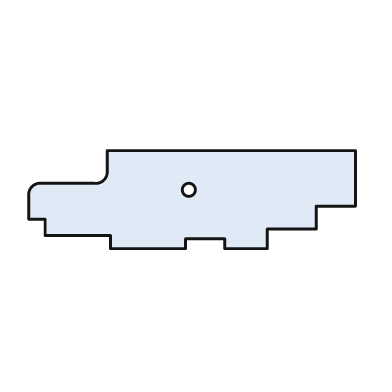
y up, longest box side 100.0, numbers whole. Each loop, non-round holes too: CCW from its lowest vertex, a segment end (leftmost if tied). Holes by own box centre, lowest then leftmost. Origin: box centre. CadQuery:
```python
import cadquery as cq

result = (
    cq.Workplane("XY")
    .moveTo(-25.0, -15.0)
    .lineTo(-2.0, -15.0)
    .lineTo(-2.0, -12.0)
    .lineTo(10.0, -12.0)
    .lineTo(10.0, -15.0)
    .lineTo(23.0, -15.0)
    .lineTo(23.0, -9.0)
    .lineTo(38.0, -9.0)
    .lineTo(38.0, -2.0)
    .lineTo(50.0, -2.0)
    .lineTo(50.0, 15.0)
    .lineTo(-26.0, 15.0)
    .lineTo(-26.0, 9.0)
    .threePointArc((-27.0, 6.0), (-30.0, 5.0))
    .lineTo(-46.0, 5.0)
    .threePointArc((-49.0, 4.0), (-50.0, 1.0))
    .lineTo(-50.0, -6.0)
    .lineTo(-45.0, -6.0)
    .lineTo(-45.0, -11.0)
    .lineTo(-25.0, -11.0)
    .close()
    .moveTo(-1.0, 3.0)
    .circle(2.0)
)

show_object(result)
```